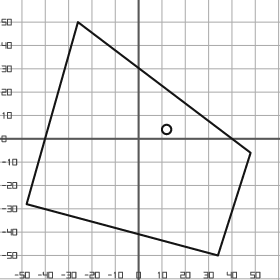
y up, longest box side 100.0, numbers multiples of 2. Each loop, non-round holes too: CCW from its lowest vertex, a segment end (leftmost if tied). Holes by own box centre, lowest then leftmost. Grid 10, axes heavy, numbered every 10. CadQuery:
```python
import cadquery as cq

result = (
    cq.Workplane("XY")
    .moveTo(34.0, -50.0)
    .lineTo(48.0, -6.0)
    .lineTo(-26.0, 50.0)
    .lineTo(-48.0, -28.0)
    .close()
    .moveTo(12.0, 4.0)
    .circle(2.0)
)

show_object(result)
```